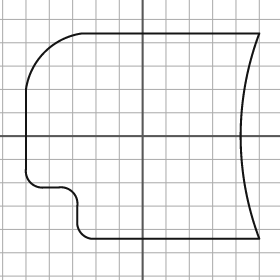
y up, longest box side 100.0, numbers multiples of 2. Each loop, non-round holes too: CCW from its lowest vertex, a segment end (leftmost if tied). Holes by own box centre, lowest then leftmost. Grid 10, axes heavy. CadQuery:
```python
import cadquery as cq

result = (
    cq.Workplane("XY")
    .moveTo(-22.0, -44.0)
    .lineTo(50.0, -44.0)
    .threePointArc((42.0, 0.0), (50.0, 44.0))
    .lineTo(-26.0, 44.0)
    .threePointArc((-42.0, 36.0), (-50.0, 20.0))
    .lineTo(-50.0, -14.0)
    .threePointArc((-48.0, -20.0), (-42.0, -22.0))
    .lineTo(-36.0, -22.0)
    .threePointArc((-30.0, -24.0), (-28.0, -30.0))
    .lineTo(-28.0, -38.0)
    .threePointArc((-26.0, -42.0), (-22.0, -44.0))
    .close()
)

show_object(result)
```